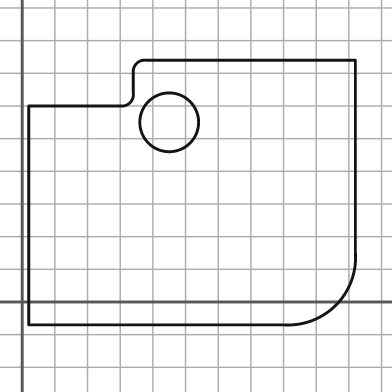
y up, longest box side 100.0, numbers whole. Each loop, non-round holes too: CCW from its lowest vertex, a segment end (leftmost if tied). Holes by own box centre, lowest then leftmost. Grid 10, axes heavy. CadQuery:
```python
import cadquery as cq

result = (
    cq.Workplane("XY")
    .moveTo(2.0, -7.0)
    .lineTo(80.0, -7.0)
    .threePointArc((96.0, -1.0), (102.0, 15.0))
    .lineTo(102.0, 74.0)
    .lineTo(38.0, 74.0)
    .threePointArc((35.0, 73.0), (34.0, 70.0))
    .lineTo(34.0, 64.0)
    .threePointArc((33.0, 61.0), (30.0, 60.0))
    .lineTo(2.0, 60.0)
    .close()
    .moveTo(45.0, 55.0)
    .circle(9.0)
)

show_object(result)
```